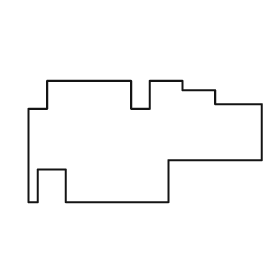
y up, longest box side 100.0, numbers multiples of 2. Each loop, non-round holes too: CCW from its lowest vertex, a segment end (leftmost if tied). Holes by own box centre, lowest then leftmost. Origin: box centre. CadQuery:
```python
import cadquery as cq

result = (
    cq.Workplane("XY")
    .moveTo(-50.0, -26.0)
    .lineTo(-46.0, -26.0)
    .lineTo(-46.0, -12.0)
    .lineTo(-34.0, -12.0)
    .lineTo(-34.0, -26.0)
    .lineTo(10.0, -26.0)
    .lineTo(10.0, -8.0)
    .lineTo(50.0, -8.0)
    .lineTo(50.0, 16.0)
    .lineTo(30.0, 16.0)
    .lineTo(30.0, 22.0)
    .lineTo(16.0, 22.0)
    .lineTo(16.0, 26.0)
    .lineTo(2.0, 26.0)
    .lineTo(2.0, 14.0)
    .lineTo(-6.0, 14.0)
    .lineTo(-6.0, 26.0)
    .lineTo(-42.0, 26.0)
    .lineTo(-42.0, 14.0)
    .lineTo(-50.0, 14.0)
    .close()
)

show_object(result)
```